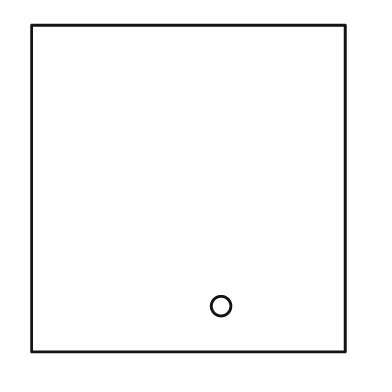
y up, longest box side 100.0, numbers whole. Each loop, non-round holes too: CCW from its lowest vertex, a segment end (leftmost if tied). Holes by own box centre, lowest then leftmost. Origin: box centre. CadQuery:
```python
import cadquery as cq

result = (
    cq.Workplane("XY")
    .moveTo(-48.0, -50.0)
    .lineTo(48.0, -50.0)
    .lineTo(48.0, 50.0)
    .lineTo(-48.0, 50.0)
    .close()
    .moveTo(10.0, -36.0)
    .circle(3.0)
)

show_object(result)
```